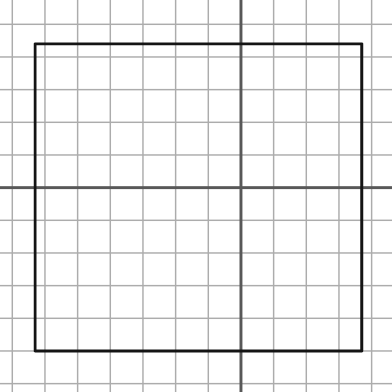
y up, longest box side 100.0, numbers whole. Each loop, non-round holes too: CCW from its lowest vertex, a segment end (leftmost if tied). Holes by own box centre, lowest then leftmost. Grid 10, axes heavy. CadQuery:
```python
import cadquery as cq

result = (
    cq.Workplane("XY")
    .moveTo(-63.0, -50.0)
    .lineTo(37.0, -50.0)
    .lineTo(37.0, 44.0)
    .lineTo(-63.0, 44.0)
    .close()
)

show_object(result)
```